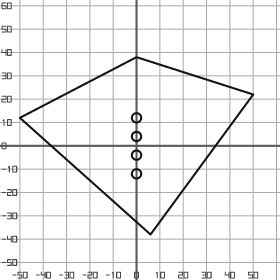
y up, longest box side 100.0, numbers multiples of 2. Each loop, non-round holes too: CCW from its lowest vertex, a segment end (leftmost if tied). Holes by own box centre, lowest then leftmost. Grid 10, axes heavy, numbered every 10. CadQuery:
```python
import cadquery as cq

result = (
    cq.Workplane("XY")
    .moveTo(6.0, -38.0)
    .lineTo(50.0, 22.0)
    .lineTo(0.0, 38.0)
    .lineTo(-50.0, 12.0)
    .close()
    .moveTo(0.0, -12.0)
    .circle(2.0)
    .moveTo(0.0, -4.0)
    .circle(2.0)
    .moveTo(0.0, 4.0)
    .circle(2.0)
    .moveTo(0.0, 12.0)
    .circle(2.0)
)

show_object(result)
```